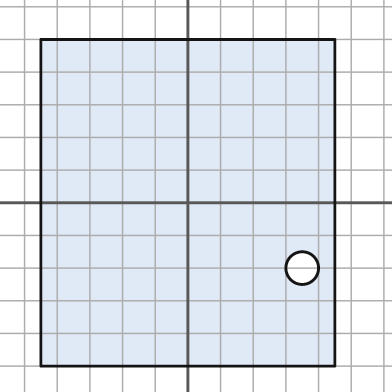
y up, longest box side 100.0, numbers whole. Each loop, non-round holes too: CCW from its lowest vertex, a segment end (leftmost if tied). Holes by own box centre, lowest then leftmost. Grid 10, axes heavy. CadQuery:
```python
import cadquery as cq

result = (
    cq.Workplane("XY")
    .moveTo(-45.0, -50.0)
    .lineTo(45.0, -50.0)
    .lineTo(45.0, 50.0)
    .lineTo(-45.0, 50.0)
    .close()
    .moveTo(35.0, -20.0)
    .circle(5.0)
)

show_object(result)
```